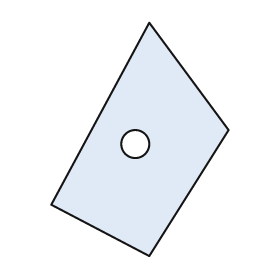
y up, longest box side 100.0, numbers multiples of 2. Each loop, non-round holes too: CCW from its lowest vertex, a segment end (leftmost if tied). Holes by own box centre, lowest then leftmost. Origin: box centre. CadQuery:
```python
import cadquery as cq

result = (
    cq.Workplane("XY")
    .moveTo(4.0, -50.0)
    .lineTo(38.0, 4.0)
    .lineTo(4.0, 50.0)
    .lineTo(-38.0, -28.0)
    .close()
    .moveTo(-2.0, -2.0)
    .circle(6.0)
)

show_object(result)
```